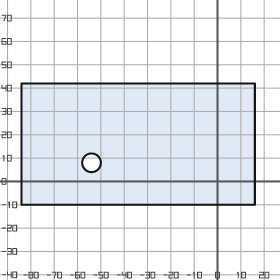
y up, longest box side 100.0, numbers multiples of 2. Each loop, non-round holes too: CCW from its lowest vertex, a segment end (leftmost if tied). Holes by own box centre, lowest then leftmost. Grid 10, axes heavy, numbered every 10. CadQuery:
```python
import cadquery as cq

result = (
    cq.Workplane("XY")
    .moveTo(-84.0, -10.0)
    .lineTo(16.0, -10.0)
    .lineTo(16.0, 42.0)
    .lineTo(-84.0, 42.0)
    .close()
    .moveTo(-54.0, 8.0)
    .circle(4.0)
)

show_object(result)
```